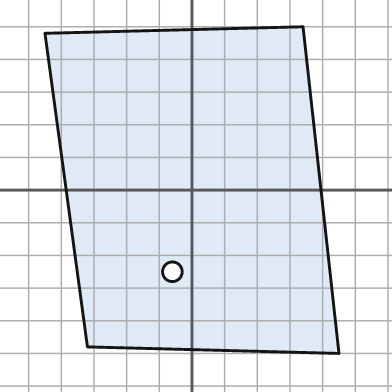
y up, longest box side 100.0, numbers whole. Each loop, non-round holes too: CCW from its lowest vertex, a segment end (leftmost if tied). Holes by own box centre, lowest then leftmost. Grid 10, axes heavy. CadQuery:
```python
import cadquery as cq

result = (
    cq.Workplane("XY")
    .moveTo(45.0, -50.0)
    .lineTo(34.0, 50.0)
    .lineTo(-45.0, 48.0)
    .lineTo(-32.0, -48.0)
    .close()
    .moveTo(-6.0, -25.0)
    .circle(3.0)
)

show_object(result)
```